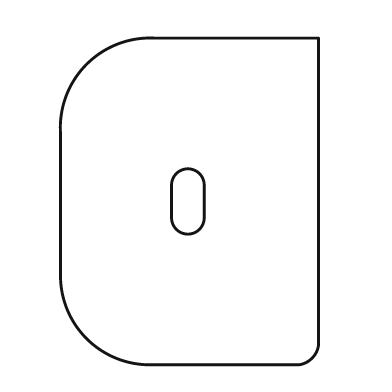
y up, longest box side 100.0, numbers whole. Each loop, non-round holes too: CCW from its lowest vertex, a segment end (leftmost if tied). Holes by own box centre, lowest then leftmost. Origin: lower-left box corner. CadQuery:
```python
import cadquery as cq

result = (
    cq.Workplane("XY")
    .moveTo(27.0, 0.0)
    .lineTo(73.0, 0.0)
    .threePointArc((77.0, 2.0), (79.0, 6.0))
    .lineTo(79.0, 100.0)
    .lineTo(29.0, 100.0)
    .threePointArc((8.0, 92.0), (0.0, 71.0))
    .lineTo(0.0, 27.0)
    .threePointArc((8.0, 8.0), (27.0, 0.0))
    .close()
    .moveTo(34.0, 45.0)
    .threePointArc((39.0, 40.0), (44.0, 45.0))
    .lineTo(44.0, 55.0)
    .threePointArc((39.0, 60.0), (34.0, 55.0))
    .close()
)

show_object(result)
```